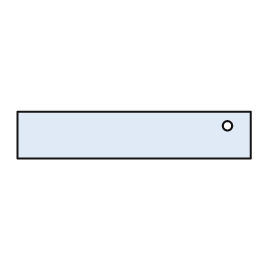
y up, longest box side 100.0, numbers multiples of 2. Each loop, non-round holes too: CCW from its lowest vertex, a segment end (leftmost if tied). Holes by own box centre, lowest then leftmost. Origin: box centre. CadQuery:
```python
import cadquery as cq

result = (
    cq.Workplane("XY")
    .moveTo(-50.0, -10.0)
    .lineTo(50.0, -10.0)
    .lineTo(50.0, 10.0)
    .lineTo(-50.0, 10.0)
    .close()
    .moveTo(40.0, 4.0)
    .circle(2.0)
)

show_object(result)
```